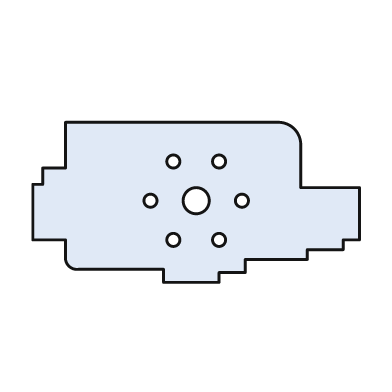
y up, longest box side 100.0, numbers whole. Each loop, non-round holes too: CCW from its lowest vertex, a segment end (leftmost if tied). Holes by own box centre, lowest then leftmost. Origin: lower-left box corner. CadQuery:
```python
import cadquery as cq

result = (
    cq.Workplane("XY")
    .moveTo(40.0, 0.0)
    .lineTo(57.0, 0.0)
    .lineTo(57.0, 3.0)
    .lineTo(65.0, 3.0)
    .lineTo(65.0, 7.0)
    .lineTo(84.0, 7.0)
    .lineTo(84.0, 10.0)
    .lineTo(95.0, 10.0)
    .lineTo(95.0, 13.0)
    .lineTo(100.0, 13.0)
    .lineTo(100.0, 29.0)
    .lineTo(82.0, 29.0)
    .lineTo(82.0, 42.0)
    .threePointArc((80.0, 47.0), (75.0, 49.0))
    .lineTo(10.0, 49.0)
    .lineTo(10.0, 35.0)
    .lineTo(3.0, 35.0)
    .lineTo(3.0, 30.0)
    .lineTo(0.0, 30.0)
    .lineTo(0.0, 13.0)
    .lineTo(10.0, 13.0)
    .lineTo(10.0, 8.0)
    .threePointArc((11.0, 5.0), (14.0, 4.0))
    .lineTo(40.0, 4.0)
    .close()
    .moveTo(43.0, 13.0)
    .circle(2.0)
    .moveTo(57.0, 13.0)
    .circle(2.0)
    .moveTo(36.0, 25.0)
    .circle(2.0)
    .moveTo(50.0, 25.0)
    .circle(4.0)
    .moveTo(64.0, 25.0)
    .circle(2.0)
    .moveTo(43.0, 37.0)
    .circle(2.0)
    .moveTo(57.0, 37.0)
    .circle(2.0)
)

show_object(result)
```